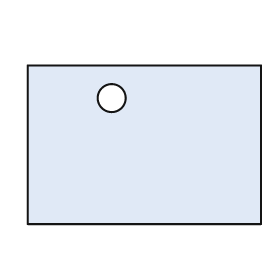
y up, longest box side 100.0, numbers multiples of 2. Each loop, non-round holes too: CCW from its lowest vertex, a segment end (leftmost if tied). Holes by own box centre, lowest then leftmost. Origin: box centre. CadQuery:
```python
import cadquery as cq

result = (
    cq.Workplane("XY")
    .moveTo(-50.0, -34.0)
    .lineTo(50.0, -34.0)
    .lineTo(50.0, 34.0)
    .lineTo(-50.0, 34.0)
    .close()
    .moveTo(-14.0, 20.0)
    .circle(6.0)
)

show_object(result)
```